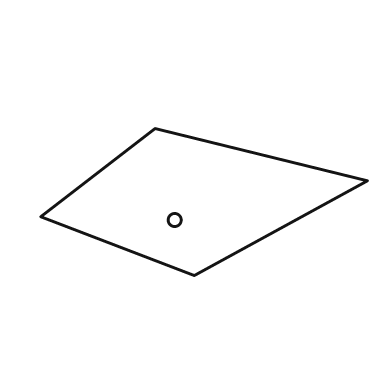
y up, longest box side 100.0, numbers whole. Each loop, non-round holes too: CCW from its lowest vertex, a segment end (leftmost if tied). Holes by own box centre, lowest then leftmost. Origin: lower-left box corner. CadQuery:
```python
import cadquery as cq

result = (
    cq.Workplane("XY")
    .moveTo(47.0, 0.0)
    .lineTo(100.0, 29.0)
    .lineTo(35.0, 45.0)
    .lineTo(0.0, 18.0)
    .close()
    .moveTo(41.0, 17.0)
    .circle(2.0)
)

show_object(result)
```